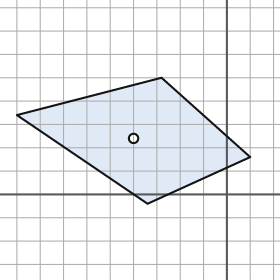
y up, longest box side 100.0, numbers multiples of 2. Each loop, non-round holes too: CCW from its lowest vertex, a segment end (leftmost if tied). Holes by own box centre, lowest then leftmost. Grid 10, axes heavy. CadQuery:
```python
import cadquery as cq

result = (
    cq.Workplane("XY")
    .moveTo(-34.0, -4.0)
    .lineTo(10.0, 16.0)
    .lineTo(-28.0, 50.0)
    .lineTo(-90.0, 34.0)
    .close()
    .moveTo(-40.0, 24.0)
    .circle(2.0)
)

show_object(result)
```